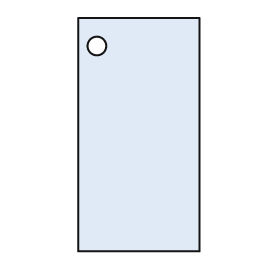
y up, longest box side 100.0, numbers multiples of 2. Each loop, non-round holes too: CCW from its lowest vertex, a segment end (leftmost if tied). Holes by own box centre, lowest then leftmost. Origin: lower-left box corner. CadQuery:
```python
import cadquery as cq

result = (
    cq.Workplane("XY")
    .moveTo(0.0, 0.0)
    .lineTo(52.0, 0.0)
    .lineTo(52.0, 100.0)
    .lineTo(0.0, 100.0)
    .close()
    .moveTo(8.0, 88.0)
    .circle(4.0)
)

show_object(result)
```